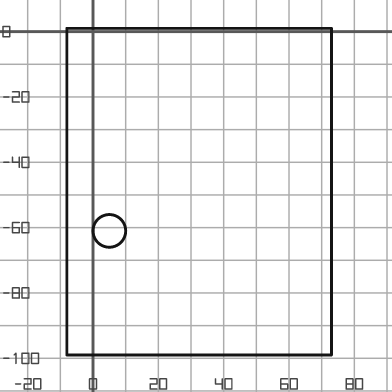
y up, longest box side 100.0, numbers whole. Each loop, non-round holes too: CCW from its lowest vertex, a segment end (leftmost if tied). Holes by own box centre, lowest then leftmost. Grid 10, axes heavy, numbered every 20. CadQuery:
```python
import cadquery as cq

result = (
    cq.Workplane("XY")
    .moveTo(-8.0, -99.0)
    .lineTo(73.0, -99.0)
    .lineTo(73.0, 1.0)
    .lineTo(-8.0, 1.0)
    .close()
    .moveTo(5.0, -61.0)
    .circle(5.0)
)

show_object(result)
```